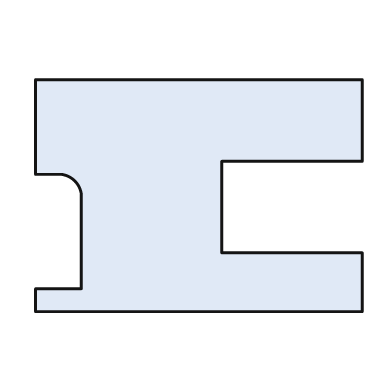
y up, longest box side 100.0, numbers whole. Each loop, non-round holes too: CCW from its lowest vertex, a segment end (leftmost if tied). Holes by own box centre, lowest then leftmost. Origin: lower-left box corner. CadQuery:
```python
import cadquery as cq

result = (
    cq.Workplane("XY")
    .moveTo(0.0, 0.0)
    .lineTo(100.0, 0.0)
    .lineTo(100.0, 18.0)
    .lineTo(57.0, 18.0)
    .lineTo(57.0, 46.0)
    .lineTo(100.0, 46.0)
    .lineTo(100.0, 71.0)
    .lineTo(0.0, 71.0)
    .lineTo(0.0, 42.0)
    .lineTo(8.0, 42.0)
    .threePointArc((12.0, 40.0), (14.0, 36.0))
    .lineTo(14.0, 7.0)
    .lineTo(0.0, 7.0)
    .close()
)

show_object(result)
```